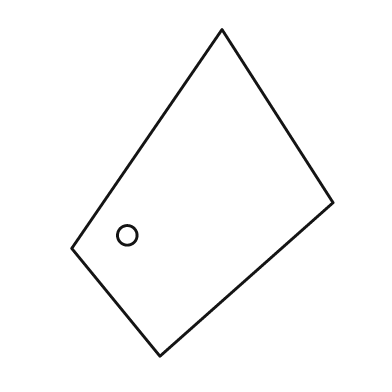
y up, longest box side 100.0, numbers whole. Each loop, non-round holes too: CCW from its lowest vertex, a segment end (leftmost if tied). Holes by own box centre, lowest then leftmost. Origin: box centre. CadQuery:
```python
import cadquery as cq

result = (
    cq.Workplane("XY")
    .moveTo(-13.0, -50.0)
    .lineTo(40.0, -3.0)
    .lineTo(6.0, 50.0)
    .lineTo(-40.0, -17.0)
    .close()
    .moveTo(-23.0, -13.0)
    .circle(3.0)
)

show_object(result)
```